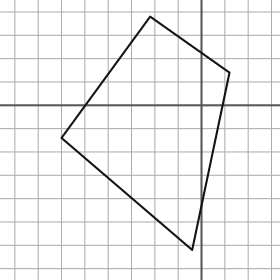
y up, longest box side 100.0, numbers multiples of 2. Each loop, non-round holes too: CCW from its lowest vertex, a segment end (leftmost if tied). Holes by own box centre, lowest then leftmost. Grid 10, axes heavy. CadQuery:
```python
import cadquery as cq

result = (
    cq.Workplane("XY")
    .moveTo(-4.0, -62.0)
    .lineTo(12.0, 14.0)
    .lineTo(-22.0, 38.0)
    .lineTo(-60.0, -14.0)
    .close()
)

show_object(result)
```